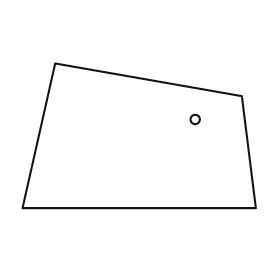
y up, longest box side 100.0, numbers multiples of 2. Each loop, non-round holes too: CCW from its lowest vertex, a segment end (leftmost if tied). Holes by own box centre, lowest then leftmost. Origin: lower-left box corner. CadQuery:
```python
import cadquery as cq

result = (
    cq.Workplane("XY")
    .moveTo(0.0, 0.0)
    .lineTo(100.0, 0.0)
    .lineTo(94.0, 48.0)
    .lineTo(14.0, 62.0)
    .close()
    .moveTo(74.0, 38.0)
    .circle(2.0)
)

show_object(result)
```